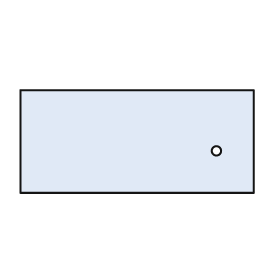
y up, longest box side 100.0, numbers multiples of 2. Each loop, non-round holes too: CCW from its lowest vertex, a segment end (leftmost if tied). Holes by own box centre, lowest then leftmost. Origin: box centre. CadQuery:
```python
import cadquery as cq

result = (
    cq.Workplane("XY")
    .moveTo(-50.0, -22.0)
    .lineTo(50.0, -22.0)
    .lineTo(50.0, 22.0)
    .lineTo(-50.0, 22.0)
    .close()
    .moveTo(34.0, -4.0)
    .circle(2.0)
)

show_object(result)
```